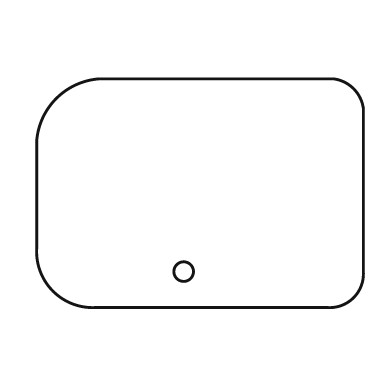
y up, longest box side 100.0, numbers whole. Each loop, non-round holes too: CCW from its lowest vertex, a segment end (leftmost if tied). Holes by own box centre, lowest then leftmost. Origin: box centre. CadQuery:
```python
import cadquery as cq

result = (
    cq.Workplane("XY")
    .moveTo(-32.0, -35.0)
    .lineTo(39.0, -35.0)
    .threePointArc((47.0, -32.0), (50.0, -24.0))
    .lineTo(50.0, 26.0)
    .threePointArc((47.0, 32.0), (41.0, 35.0))
    .lineTo(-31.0, 35.0)
    .threePointArc((-44.0, 29.0), (-50.0, 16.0))
    .lineTo(-50.0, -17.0)
    .threePointArc((-45.0, -30.0), (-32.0, -35.0))
    .close()
    .moveTo(-5.0, -24.0)
    .circle(3.0)
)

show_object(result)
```